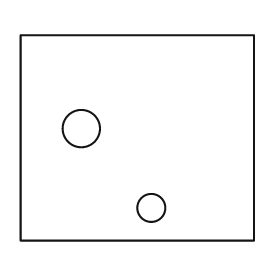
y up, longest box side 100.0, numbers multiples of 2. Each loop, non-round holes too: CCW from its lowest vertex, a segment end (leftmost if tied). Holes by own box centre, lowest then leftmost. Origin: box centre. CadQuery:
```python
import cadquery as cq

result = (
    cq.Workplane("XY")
    .moveTo(-50.0, -44.0)
    .lineTo(50.0, -44.0)
    .lineTo(50.0, 44.0)
    .lineTo(-50.0, 44.0)
    .close()
    .moveTo(6.0, -30.0)
    .circle(6.0)
    .moveTo(-24.0, 4.0)
    .circle(8.0)
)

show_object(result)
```